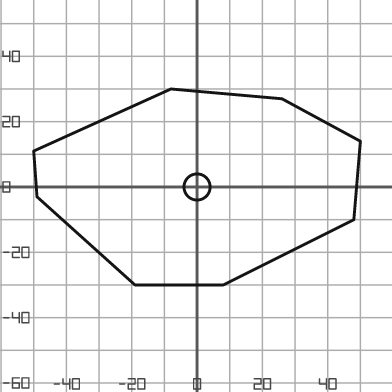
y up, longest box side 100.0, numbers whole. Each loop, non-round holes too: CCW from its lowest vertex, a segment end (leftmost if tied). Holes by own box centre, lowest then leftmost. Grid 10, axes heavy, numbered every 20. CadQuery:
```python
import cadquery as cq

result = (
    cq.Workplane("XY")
    .moveTo(-19.0, -30.0)
    .lineTo(8.0, -30.0)
    .lineTo(48.0, -10.0)
    .lineTo(50.0, 14.0)
    .lineTo(26.0, 27.0)
    .lineTo(-8.0, 30.0)
    .lineTo(-50.0, 11.0)
    .lineTo(-49.0, -3.0)
    .close()
    .moveTo(0.0, 0.0)
    .circle(4.0)
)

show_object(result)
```